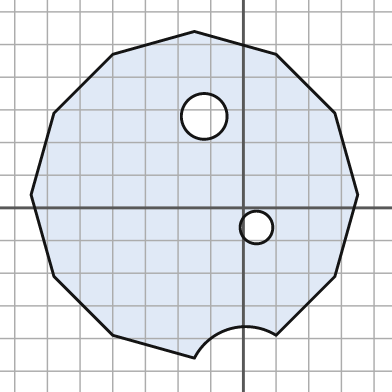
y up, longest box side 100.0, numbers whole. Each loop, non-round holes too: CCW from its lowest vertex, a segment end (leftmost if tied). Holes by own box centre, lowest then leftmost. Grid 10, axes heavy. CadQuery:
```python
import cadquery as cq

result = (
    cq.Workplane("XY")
    .moveTo(-15.0, -46.0)
    .threePointArc((-4.0, -37.0), (10.0, -39.0))
    .lineTo(28.0, -21.0)
    .lineTo(35.0, 4.0)
    .lineTo(28.0, 29.0)
    .lineTo(10.0, 47.0)
    .lineTo(-15.0, 54.0)
    .lineTo(-40.0, 47.0)
    .lineTo(-58.0, 29.0)
    .lineTo(-65.0, 4.0)
    .lineTo(-58.0, -21.0)
    .lineTo(-40.0, -39.0)
    .close()
    .moveTo(4.0, -6.0)
    .circle(5.0)
    .moveTo(-12.0, 28.0)
    .circle(7.0)
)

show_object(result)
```